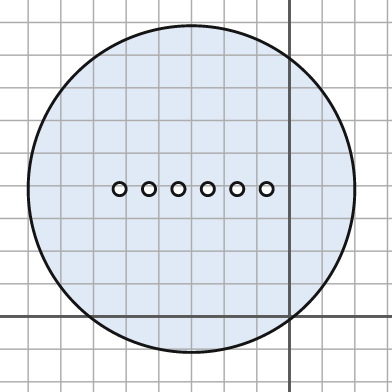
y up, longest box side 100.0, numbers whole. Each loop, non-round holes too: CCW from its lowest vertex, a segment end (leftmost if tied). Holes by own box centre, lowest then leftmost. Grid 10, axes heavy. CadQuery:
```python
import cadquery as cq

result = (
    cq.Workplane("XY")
    .moveTo(-30.0, 39.0)
    .circle(50.0)
    .moveTo(-52.0, 39.0)
    .circle(2.0)
    .moveTo(-43.0, 39.0)
    .circle(2.0)
    .moveTo(-34.0, 39.0)
    .circle(2.0)
    .moveTo(-25.0, 39.0)
    .circle(2.0)
    .moveTo(-16.0, 39.0)
    .circle(2.0)
    .moveTo(-7.0, 39.0)
    .circle(2.0)
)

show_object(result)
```